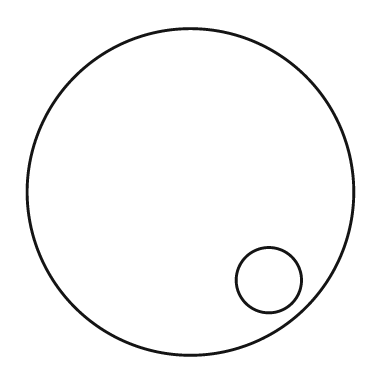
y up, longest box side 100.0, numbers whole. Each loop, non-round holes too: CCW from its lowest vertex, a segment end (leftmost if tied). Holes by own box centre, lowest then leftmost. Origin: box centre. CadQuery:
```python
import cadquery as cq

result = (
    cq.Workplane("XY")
    .moveTo(0.0, 0.0)
    .circle(50.0)
    .moveTo(24.0, -27.0)
    .circle(10.0)
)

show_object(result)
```